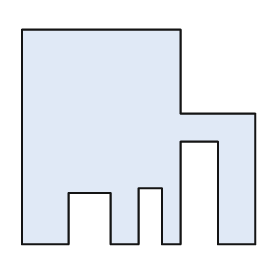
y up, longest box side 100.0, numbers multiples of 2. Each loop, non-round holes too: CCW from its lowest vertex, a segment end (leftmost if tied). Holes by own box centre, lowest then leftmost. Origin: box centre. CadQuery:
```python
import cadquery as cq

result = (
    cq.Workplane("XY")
    .moveTo(-50.0, -46.0)
    .lineTo(-30.0, -46.0)
    .lineTo(-30.0, -24.0)
    .lineTo(-12.0, -24.0)
    .lineTo(-12.0, -46.0)
    .lineTo(0.0, -46.0)
    .lineTo(0.0, -22.0)
    .lineTo(10.0, -22.0)
    .lineTo(10.0, -46.0)
    .lineTo(18.0, -46.0)
    .lineTo(18.0, -2.0)
    .lineTo(34.0, -2.0)
    .lineTo(34.0, -46.0)
    .lineTo(50.0, -46.0)
    .lineTo(50.0, 10.0)
    .lineTo(18.0, 10.0)
    .lineTo(18.0, 46.0)
    .lineTo(-50.0, 46.0)
    .close()
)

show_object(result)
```